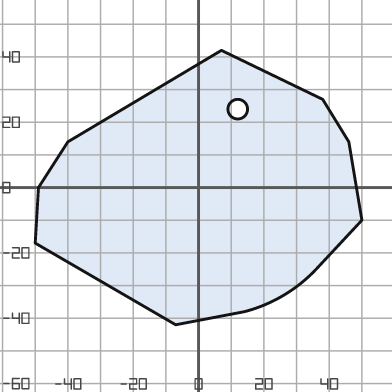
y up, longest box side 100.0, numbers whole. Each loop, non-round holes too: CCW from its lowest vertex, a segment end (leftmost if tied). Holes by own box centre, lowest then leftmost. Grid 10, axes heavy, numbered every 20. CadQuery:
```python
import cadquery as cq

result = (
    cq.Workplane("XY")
    .moveTo(-7.0, -42.0)
    .lineTo(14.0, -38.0)
    .threePointArc((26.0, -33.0), (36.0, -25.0))
    .lineTo(50.0, -10.0)
    .lineTo(46.0, 14.0)
    .lineTo(38.0, 27.0)
    .lineTo(7.0, 42.0)
    .lineTo(-40.0, 14.0)
    .lineTo(-49.0, 0.0)
    .lineTo(-50.0, -17.0)
    .close()
    .moveTo(12.0, 24.0)
    .circle(3.0)
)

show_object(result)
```